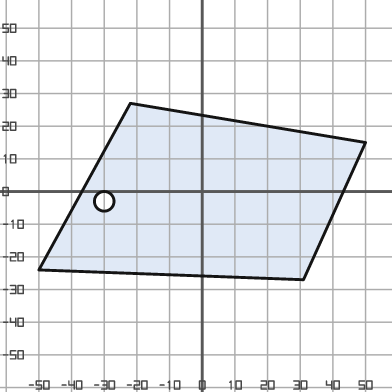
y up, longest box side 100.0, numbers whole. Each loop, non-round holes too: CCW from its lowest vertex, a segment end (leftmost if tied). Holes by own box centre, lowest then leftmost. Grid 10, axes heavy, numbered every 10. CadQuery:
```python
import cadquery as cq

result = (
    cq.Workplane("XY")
    .moveTo(31.0, -27.0)
    .lineTo(50.0, 15.0)
    .lineTo(-22.0, 27.0)
    .lineTo(-50.0, -24.0)
    .close()
    .moveTo(-30.0, -3.0)
    .circle(3.0)
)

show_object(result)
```